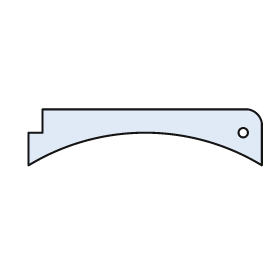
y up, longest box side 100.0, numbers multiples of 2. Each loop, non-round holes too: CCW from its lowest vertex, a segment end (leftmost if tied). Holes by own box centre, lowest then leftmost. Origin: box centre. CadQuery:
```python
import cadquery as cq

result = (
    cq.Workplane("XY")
    .moveTo(-50.0, -12.0)
    .threePointArc((0.0, 2.0), (50.0, -12.0))
    .lineTo(50.0, 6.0)
    .threePointArc((48.0, 10.0), (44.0, 12.0))
    .lineTo(-44.0, 12.0)
    .lineTo(-44.0, 2.0)
    .lineTo(-50.0, 2.0)
    .close()
    .moveTo(42.0, 2.0)
    .circle(2.0)
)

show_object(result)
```